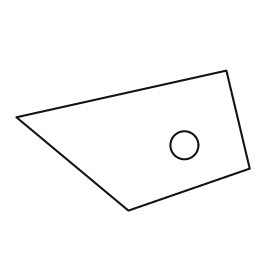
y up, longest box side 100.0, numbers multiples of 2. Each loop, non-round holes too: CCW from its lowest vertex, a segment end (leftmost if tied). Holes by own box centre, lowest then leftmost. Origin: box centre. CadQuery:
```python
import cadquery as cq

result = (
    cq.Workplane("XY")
    .moveTo(-2.0, -30.0)
    .lineTo(50.0, -12.0)
    .lineTo(40.0, 30.0)
    .lineTo(-50.0, 10.0)
    .close()
    .moveTo(22.0, -2.0)
    .circle(6.0)
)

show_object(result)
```